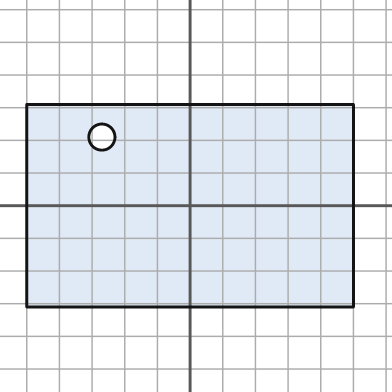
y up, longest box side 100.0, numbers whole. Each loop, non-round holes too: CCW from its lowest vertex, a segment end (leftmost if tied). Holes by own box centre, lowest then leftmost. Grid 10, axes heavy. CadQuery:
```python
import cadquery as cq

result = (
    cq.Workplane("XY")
    .moveTo(-50.0, -31.0)
    .lineTo(50.0, -31.0)
    .lineTo(50.0, 31.0)
    .lineTo(-50.0, 31.0)
    .close()
    .moveTo(-27.0, 21.0)
    .circle(4.0)
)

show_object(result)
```